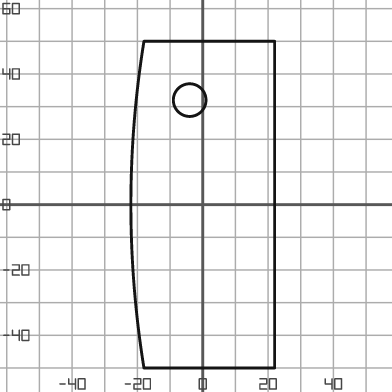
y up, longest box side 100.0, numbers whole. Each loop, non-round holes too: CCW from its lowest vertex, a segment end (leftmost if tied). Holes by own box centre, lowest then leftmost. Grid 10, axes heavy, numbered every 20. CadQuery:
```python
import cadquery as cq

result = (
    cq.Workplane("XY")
    .moveTo(-18.0, -50.0)
    .lineTo(22.0, -50.0)
    .lineTo(22.0, 50.0)
    .lineTo(-18.0, 50.0)
    .threePointArc((-22.0, 0.0), (-18.0, -50.0))
    .close()
    .moveTo(-4.0, 32.0)
    .circle(5.0)
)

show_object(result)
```